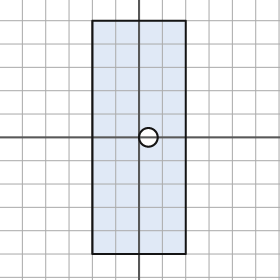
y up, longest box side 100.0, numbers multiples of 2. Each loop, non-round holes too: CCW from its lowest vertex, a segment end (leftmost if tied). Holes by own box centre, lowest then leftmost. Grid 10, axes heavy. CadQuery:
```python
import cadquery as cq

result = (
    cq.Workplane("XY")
    .moveTo(-20.0, -50.0)
    .lineTo(20.0, -50.0)
    .lineTo(20.0, 50.0)
    .lineTo(-20.0, 50.0)
    .close()
    .moveTo(4.0, 0.0)
    .circle(4.0)
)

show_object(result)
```